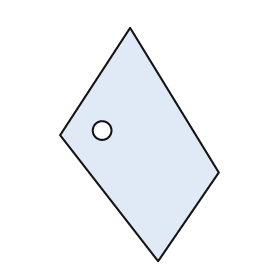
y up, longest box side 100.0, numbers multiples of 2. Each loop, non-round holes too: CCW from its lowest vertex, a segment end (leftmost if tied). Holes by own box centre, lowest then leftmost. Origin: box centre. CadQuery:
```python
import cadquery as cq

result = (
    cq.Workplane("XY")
    .moveTo(8.0, -50.0)
    .lineTo(34.0, -12.0)
    .lineTo(-4.0, 50.0)
    .lineTo(-34.0, 4.0)
    .close()
    .moveTo(-16.0, 6.0)
    .circle(4.0)
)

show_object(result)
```